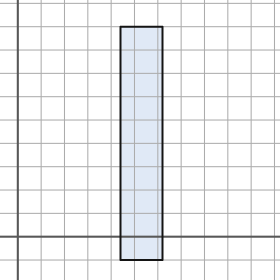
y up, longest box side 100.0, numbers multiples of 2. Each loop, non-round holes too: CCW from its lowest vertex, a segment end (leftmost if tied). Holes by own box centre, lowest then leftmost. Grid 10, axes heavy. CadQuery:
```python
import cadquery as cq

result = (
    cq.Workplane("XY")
    .moveTo(44.0, -10.0)
    .lineTo(62.0, -10.0)
    .lineTo(62.0, 90.0)
    .lineTo(44.0, 90.0)
    .close()
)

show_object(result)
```